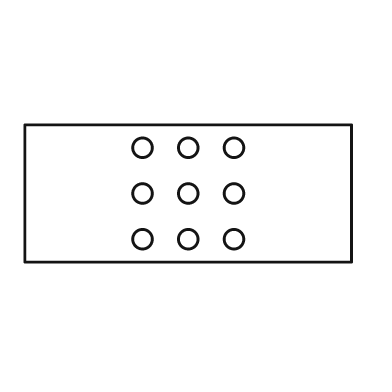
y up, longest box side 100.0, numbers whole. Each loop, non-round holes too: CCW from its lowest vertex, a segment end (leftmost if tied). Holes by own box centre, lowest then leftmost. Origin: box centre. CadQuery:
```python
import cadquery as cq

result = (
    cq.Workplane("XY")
    .moveTo(-50.0, -21.0)
    .lineTo(50.0, -21.0)
    .lineTo(50.0, 21.0)
    .lineTo(-50.0, 21.0)
    .close()
    .moveTo(-14.0, -14.0)
    .circle(3.0)
    .moveTo(0.0, -14.0)
    .circle(3.0)
    .moveTo(14.0, -14.0)
    .circle(3.0)
    .moveTo(-14.0, 0.0)
    .circle(3.0)
    .moveTo(0.0, 0.0)
    .circle(3.0)
    .moveTo(14.0, 0.0)
    .circle(3.0)
    .moveTo(-14.0, 14.0)
    .circle(3.0)
    .moveTo(0.0, 14.0)
    .circle(3.0)
    .moveTo(14.0, 14.0)
    .circle(3.0)
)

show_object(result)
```